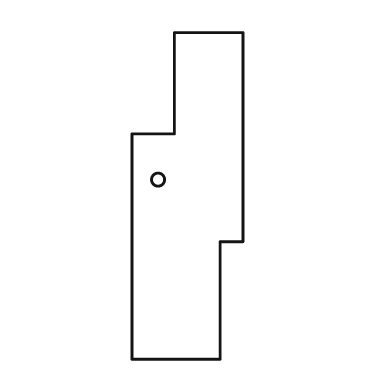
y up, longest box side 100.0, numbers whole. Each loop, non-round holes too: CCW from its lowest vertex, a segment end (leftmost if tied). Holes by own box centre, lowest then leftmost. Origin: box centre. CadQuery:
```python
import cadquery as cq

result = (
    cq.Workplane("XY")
    .moveTo(-17.0, -50.0)
    .lineTo(10.0, -50.0)
    .lineTo(10.0, -14.0)
    .lineTo(17.0, -14.0)
    .lineTo(17.0, 50.0)
    .lineTo(-4.0, 50.0)
    .lineTo(-4.0, 19.0)
    .lineTo(-17.0, 19.0)
    .close()
    .moveTo(-9.0, 5.0)
    .circle(2.0)
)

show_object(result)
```